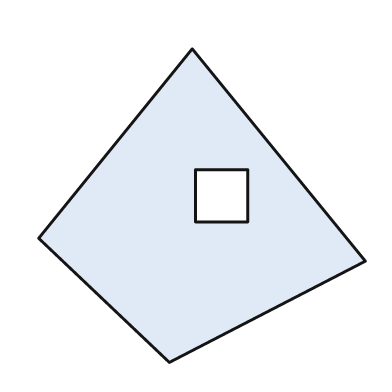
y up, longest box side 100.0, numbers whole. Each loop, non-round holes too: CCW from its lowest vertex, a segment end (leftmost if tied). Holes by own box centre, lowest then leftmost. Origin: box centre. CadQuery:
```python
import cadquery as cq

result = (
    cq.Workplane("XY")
    .moveTo(-10.0, -48.0)
    .lineTo(50.0, -17.0)
    .lineTo(-3.0, 48.0)
    .lineTo(-50.0, -10.0)
    .close()
    .moveTo(-2.0, -5.0)
    .lineTo(14.0, -5.0)
    .lineTo(14.0, 11.0)
    .lineTo(-2.0, 11.0)
    .close()
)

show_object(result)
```